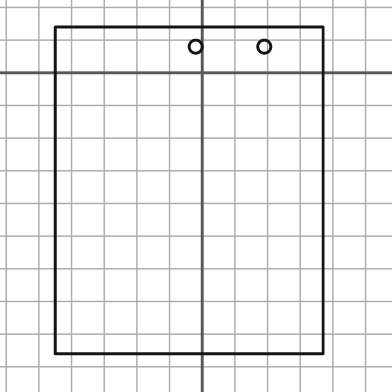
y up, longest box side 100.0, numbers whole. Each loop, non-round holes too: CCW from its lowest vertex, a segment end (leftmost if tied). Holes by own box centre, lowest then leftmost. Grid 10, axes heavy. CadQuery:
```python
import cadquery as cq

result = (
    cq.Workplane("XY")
    .moveTo(-45.0, -86.0)
    .lineTo(37.0, -86.0)
    .lineTo(37.0, 14.0)
    .lineTo(-45.0, 14.0)
    .close()
    .moveTo(-2.0, 8.0)
    .circle(2.0)
    .moveTo(19.0, 8.0)
    .circle(2.0)
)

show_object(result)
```